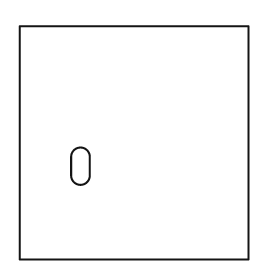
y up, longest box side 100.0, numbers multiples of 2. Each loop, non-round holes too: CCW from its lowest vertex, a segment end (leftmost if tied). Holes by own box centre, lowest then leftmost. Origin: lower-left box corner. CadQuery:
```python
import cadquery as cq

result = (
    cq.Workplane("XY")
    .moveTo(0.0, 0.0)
    .lineTo(98.0, 0.0)
    .lineTo(98.0, 100.0)
    .lineTo(0.0, 100.0)
    .close()
    .moveTo(22.0, 36.0)
    .threePointArc((26.0, 32.0), (30.0, 36.0))
    .lineTo(30.0, 44.0)
    .threePointArc((26.0, 48.0), (22.0, 44.0))
    .close()
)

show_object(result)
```